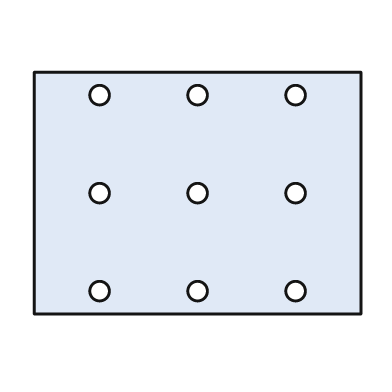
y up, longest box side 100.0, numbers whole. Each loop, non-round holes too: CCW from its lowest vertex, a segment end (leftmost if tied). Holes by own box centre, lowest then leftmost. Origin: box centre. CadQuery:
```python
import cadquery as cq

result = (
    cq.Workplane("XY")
    .moveTo(-50.0, -37.0)
    .lineTo(50.0, -37.0)
    .lineTo(50.0, 37.0)
    .lineTo(-50.0, 37.0)
    .close()
    .moveTo(-30.0, -30.0)
    .circle(3.0)
    .moveTo(0.0, -30.0)
    .circle(3.0)
    .moveTo(30.0, -30.0)
    .circle(3.0)
    .moveTo(-30.0, 0.0)
    .circle(3.0)
    .moveTo(0.0, 0.0)
    .circle(3.0)
    .moveTo(30.0, 0.0)
    .circle(3.0)
    .moveTo(-30.0, 30.0)
    .circle(3.0)
    .moveTo(0.0, 30.0)
    .circle(3.0)
    .moveTo(30.0, 30.0)
    .circle(3.0)
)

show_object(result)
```